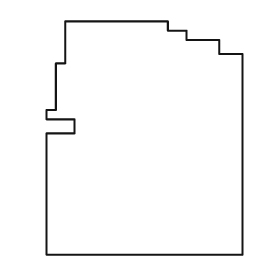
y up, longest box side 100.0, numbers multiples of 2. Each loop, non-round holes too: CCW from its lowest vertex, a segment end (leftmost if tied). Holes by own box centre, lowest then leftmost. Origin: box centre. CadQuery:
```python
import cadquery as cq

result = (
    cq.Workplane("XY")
    .moveTo(-42.0, -50.0)
    .lineTo(42.0, -50.0)
    .lineTo(42.0, 36.0)
    .lineTo(32.0, 36.0)
    .lineTo(32.0, 42.0)
    .lineTo(18.0, 42.0)
    .lineTo(18.0, 46.0)
    .lineTo(10.0, 46.0)
    .lineTo(10.0, 50.0)
    .lineTo(-34.0, 50.0)
    .lineTo(-34.0, 32.0)
    .lineTo(-38.0, 32.0)
    .lineTo(-38.0, 12.0)
    .lineTo(-42.0, 12.0)
    .lineTo(-42.0, 8.0)
    .lineTo(-30.0, 8.0)
    .lineTo(-30.0, 2.0)
    .lineTo(-42.0, 2.0)
    .close()
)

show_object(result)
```